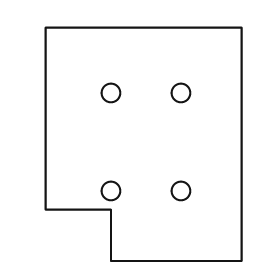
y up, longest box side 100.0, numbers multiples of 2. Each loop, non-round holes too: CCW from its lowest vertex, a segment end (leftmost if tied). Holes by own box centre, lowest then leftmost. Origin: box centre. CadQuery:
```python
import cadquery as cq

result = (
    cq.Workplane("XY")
    .moveTo(-14.0, -50.0)
    .lineTo(42.0, -50.0)
    .lineTo(42.0, 50.0)
    .lineTo(-42.0, 50.0)
    .lineTo(-42.0, -28.0)
    .lineTo(-14.0, -28.0)
    .close()
    .moveTo(-14.0, -20.0)
    .circle(4.0)
    .moveTo(16.0, -20.0)
    .circle(4.0)
    .moveTo(-14.0, 22.0)
    .circle(4.0)
    .moveTo(16.0, 22.0)
    .circle(4.0)
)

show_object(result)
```